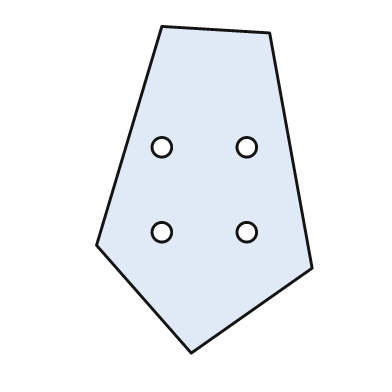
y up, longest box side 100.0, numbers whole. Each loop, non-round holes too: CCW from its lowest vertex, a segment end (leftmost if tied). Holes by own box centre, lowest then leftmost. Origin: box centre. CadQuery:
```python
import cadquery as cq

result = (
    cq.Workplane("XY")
    .moveTo(-4.0, -50.0)
    .lineTo(33.0, -24.0)
    .lineTo(20.0, 48.0)
    .lineTo(-13.0, 50.0)
    .lineTo(-33.0, -17.0)
    .close()
    .moveTo(-13.0, -13.0)
    .circle(3.0)
    .moveTo(13.0, -13.0)
    .circle(3.0)
    .moveTo(-13.0, 13.0)
    .circle(3.0)
    .moveTo(13.0, 13.0)
    .circle(3.0)
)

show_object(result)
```